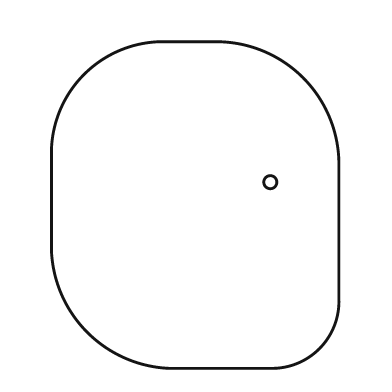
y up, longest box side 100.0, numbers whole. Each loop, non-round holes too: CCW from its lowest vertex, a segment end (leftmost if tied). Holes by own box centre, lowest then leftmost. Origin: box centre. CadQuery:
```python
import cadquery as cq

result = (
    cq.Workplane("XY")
    .moveTo(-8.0, -50.0)
    .lineTo(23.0, -50.0)
    .threePointArc((38.0, -44.0), (44.0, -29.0))
    .lineTo(44.0, 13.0)
    .threePointArc((33.0, 39.0), (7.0, 50.0))
    .lineTo(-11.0, 50.0)
    .threePointArc((-34.0, 40.0), (-44.0, 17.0))
    .lineTo(-44.0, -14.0)
    .threePointArc((-33.0, -39.0), (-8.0, -50.0))
    .close()
    .moveTo(23.0, 7.0)
    .circle(2.0)
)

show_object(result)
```